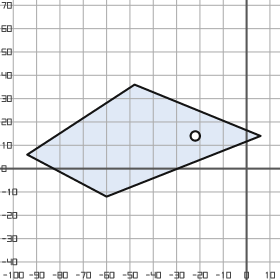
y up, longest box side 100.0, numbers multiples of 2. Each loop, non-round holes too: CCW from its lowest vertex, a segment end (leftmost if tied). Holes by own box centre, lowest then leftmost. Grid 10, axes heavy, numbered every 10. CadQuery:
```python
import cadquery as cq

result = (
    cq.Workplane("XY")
    .moveTo(-60.0, -12.0)
    .lineTo(6.0, 14.0)
    .lineTo(-48.0, 36.0)
    .lineTo(-94.0, 6.0)
    .close()
    .moveTo(-22.0, 14.0)
    .circle(2.0)
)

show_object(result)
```